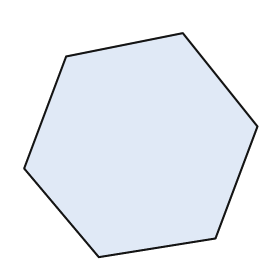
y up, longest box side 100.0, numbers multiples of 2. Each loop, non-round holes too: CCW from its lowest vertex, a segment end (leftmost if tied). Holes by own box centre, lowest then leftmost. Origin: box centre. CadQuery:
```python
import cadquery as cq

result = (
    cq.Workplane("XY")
    .moveTo(-18.0, -48.0)
    .lineTo(32.0, -40.0)
    .lineTo(50.0, 8.0)
    .lineTo(18.0, 48.0)
    .lineTo(-32.0, 38.0)
    .lineTo(-50.0, -10.0)
    .close()
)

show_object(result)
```